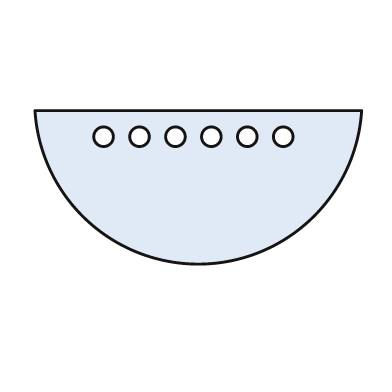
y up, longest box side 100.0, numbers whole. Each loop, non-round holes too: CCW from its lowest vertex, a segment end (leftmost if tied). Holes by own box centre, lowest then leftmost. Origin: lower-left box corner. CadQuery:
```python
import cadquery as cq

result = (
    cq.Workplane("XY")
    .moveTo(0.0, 47.0)
    .threePointArc((50.0, 0.0), (100.0, 47.0))
    .close()
    .moveTo(21.0, 39.0)
    .circle(3.0)
    .moveTo(32.0, 39.0)
    .circle(3.0)
    .moveTo(43.0, 39.0)
    .circle(3.0)
    .moveTo(54.0, 39.0)
    .circle(3.0)
    .moveTo(65.0, 39.0)
    .circle(3.0)
    .moveTo(76.0, 39.0)
    .circle(3.0)
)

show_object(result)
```